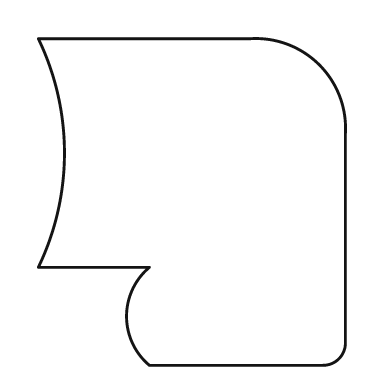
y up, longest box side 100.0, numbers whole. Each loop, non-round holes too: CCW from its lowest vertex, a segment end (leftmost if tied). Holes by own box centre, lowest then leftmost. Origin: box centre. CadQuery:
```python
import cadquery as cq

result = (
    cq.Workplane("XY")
    .moveTo(-13.0, -50.0)
    .lineTo(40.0, -50.0)
    .threePointArc((45.0, -48.0), (47.0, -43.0))
    .lineTo(47.0, 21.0)
    .threePointArc((39.0, 42.0), (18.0, 50.0))
    .lineTo(-47.0, 50.0)
    .threePointArc((-39.0, 15.0), (-47.0, -20.0))
    .lineTo(-13.0, -20.0)
    .threePointArc((-20.0, -35.0), (-13.0, -50.0))
    .close()
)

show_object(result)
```